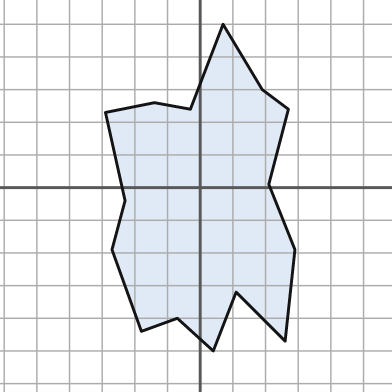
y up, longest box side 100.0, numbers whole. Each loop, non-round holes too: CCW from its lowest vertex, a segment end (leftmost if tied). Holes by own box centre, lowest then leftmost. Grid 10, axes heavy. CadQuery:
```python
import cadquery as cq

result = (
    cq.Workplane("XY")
    .moveTo(4.0, -50.0)
    .lineTo(11.0, -32.0)
    .lineTo(26.0, -47.0)
    .lineTo(29.0, -19.0)
    .lineTo(21.0, 1.0)
    .lineTo(27.0, 24.0)
    .lineTo(19.0, 30.0)
    .lineTo(7.0, 50.0)
    .lineTo(-3.0, 24.0)
    .lineTo(-14.0, 26.0)
    .lineTo(-29.0, 23.0)
    .lineTo(-23.0, -4.0)
    .lineTo(-27.0, -19.0)
    .lineTo(-18.0, -44.0)
    .lineTo(-7.0, -40.0)
    .close()
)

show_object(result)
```